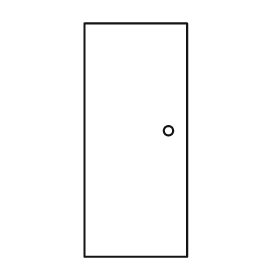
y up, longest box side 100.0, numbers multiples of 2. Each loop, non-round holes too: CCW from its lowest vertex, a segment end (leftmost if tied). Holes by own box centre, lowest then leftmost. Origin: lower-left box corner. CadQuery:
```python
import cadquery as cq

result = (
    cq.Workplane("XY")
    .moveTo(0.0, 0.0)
    .lineTo(44.0, 0.0)
    .lineTo(44.0, 100.0)
    .lineTo(0.0, 100.0)
    .close()
    .moveTo(36.0, 54.0)
    .circle(2.0)
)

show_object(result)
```